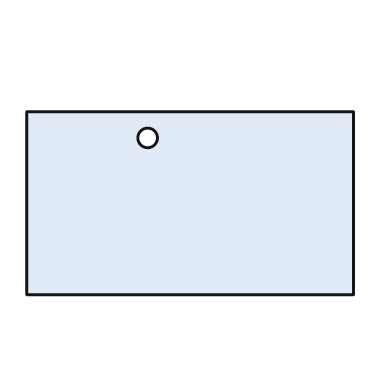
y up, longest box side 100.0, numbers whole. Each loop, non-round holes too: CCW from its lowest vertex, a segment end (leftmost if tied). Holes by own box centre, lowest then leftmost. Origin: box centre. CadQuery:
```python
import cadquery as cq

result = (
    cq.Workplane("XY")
    .moveTo(-50.0, -28.0)
    .lineTo(50.0, -28.0)
    .lineTo(50.0, 28.0)
    .lineTo(-50.0, 28.0)
    .close()
    .moveTo(-13.0, 20.0)
    .circle(3.0)
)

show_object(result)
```